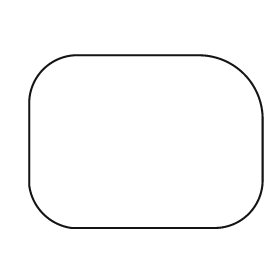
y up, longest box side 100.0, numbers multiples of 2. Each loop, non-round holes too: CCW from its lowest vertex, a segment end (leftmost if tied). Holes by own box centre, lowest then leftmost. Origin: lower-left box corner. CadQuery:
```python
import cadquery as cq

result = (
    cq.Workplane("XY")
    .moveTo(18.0, 0.0)
    .lineTo(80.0, 0.0)
    .threePointArc((94.0, 6.0), (100.0, 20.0))
    .lineTo(100.0, 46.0)
    .threePointArc((92.0, 66.0), (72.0, 74.0))
    .lineTo(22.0, 74.0)
    .threePointArc((6.0, 68.0), (0.0, 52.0))
    .lineTo(0.0, 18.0)
    .threePointArc((6.0, 6.0), (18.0, 0.0))
    .close()
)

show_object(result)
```